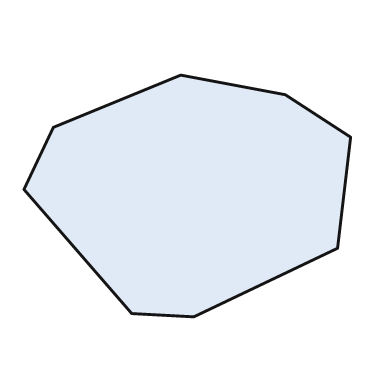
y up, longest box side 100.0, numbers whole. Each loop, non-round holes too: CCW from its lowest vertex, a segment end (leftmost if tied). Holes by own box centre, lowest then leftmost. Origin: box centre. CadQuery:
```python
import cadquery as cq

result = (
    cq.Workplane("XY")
    .moveTo(2.0, -37.0)
    .lineTo(46.0, -16.0)
    .lineTo(50.0, 18.0)
    .lineTo(30.0, 31.0)
    .lineTo(-2.0, 37.0)
    .lineTo(-41.0, 21.0)
    .lineTo(-50.0, 2.0)
    .lineTo(-17.0, -36.0)
    .close()
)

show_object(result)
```